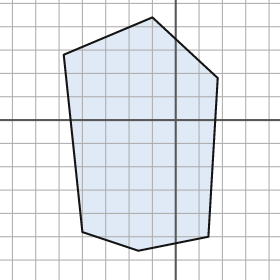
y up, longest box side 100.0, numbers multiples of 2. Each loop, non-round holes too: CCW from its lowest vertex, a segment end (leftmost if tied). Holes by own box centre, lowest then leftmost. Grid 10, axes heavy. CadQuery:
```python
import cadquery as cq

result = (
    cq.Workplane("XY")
    .moveTo(-16.0, -56.0)
    .lineTo(14.0, -50.0)
    .lineTo(18.0, 18.0)
    .lineTo(-10.0, 44.0)
    .lineTo(-48.0, 28.0)
    .lineTo(-40.0, -48.0)
    .close()
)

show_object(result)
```